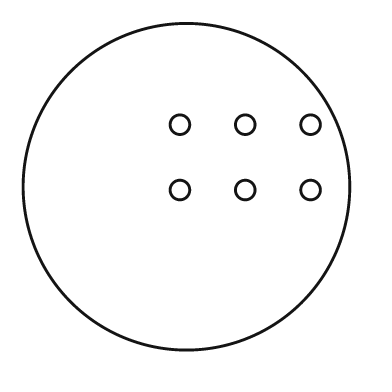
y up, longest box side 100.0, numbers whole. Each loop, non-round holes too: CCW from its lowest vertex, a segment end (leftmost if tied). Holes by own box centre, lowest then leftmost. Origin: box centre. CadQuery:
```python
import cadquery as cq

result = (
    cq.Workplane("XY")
    .moveTo(0.0, 0.0)
    .circle(50.0)
    .moveTo(-2.0, -1.0)
    .circle(3.0)
    .moveTo(18.0, -1.0)
    .circle(3.0)
    .moveTo(38.0, -1.0)
    .circle(3.0)
    .moveTo(-2.0, 19.0)
    .circle(3.0)
    .moveTo(18.0, 19.0)
    .circle(3.0)
    .moveTo(38.0, 19.0)
    .circle(3.0)
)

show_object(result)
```